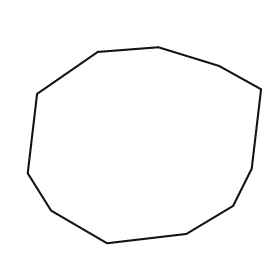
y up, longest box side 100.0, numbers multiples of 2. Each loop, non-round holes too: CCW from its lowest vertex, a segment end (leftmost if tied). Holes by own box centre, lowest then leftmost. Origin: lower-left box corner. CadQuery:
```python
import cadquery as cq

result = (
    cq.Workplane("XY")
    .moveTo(34.0, 0.0)
    .lineTo(68.0, 4.0)
    .lineTo(88.0, 16.0)
    .lineTo(96.0, 32.0)
    .lineTo(100.0, 66.0)
    .lineTo(82.0, 76.0)
    .lineTo(56.0, 84.0)
    .lineTo(30.0, 82.0)
    .lineTo(4.0, 64.0)
    .lineTo(0.0, 30.0)
    .lineTo(10.0, 14.0)
    .close()
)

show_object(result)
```